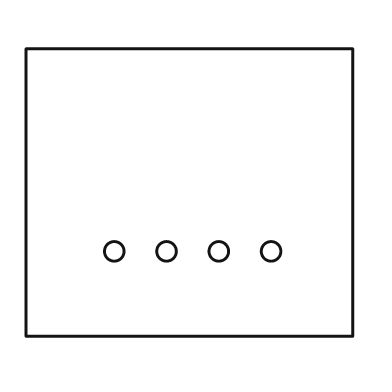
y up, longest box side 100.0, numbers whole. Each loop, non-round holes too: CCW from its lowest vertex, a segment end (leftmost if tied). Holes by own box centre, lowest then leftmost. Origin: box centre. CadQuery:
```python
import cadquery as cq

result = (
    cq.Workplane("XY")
    .moveTo(-50.0, -44.0)
    .lineTo(50.0, -44.0)
    .lineTo(50.0, 44.0)
    .lineTo(-50.0, 44.0)
    .close()
    .moveTo(-23.0, -18.0)
    .circle(3.0)
    .moveTo(-7.0, -18.0)
    .circle(3.0)
    .moveTo(9.0, -18.0)
    .circle(3.0)
    .moveTo(25.0, -18.0)
    .circle(3.0)
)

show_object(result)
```